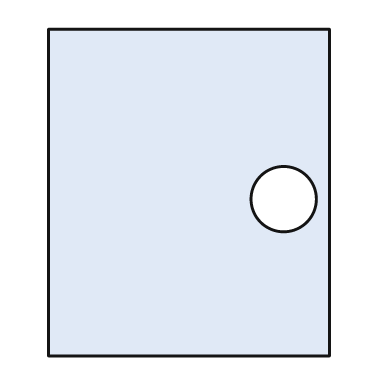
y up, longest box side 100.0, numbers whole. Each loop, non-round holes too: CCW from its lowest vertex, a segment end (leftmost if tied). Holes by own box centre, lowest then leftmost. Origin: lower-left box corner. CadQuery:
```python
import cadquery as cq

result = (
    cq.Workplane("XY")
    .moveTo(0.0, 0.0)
    .lineTo(86.0, 0.0)
    .lineTo(86.0, 100.0)
    .lineTo(0.0, 100.0)
    .close()
    .moveTo(72.0, 48.0)
    .circle(10.0)
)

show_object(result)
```